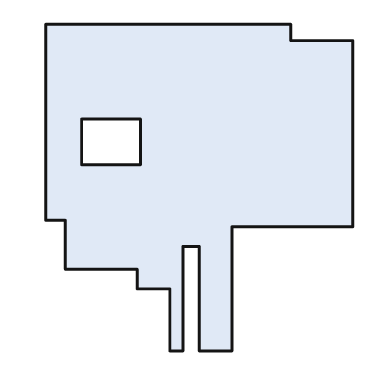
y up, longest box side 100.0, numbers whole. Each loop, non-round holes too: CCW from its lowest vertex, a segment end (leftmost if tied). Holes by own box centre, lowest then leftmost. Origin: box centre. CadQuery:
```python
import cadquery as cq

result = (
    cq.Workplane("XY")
    .moveTo(-9.0, -50.0)
    .lineTo(-5.0, -50.0)
    .lineTo(-5.0, -18.0)
    .lineTo(0.0, -18.0)
    .lineTo(0.0, -50.0)
    .lineTo(10.0, -50.0)
    .lineTo(10.0, -12.0)
    .lineTo(47.0, -12.0)
    .lineTo(47.0, 45.0)
    .lineTo(28.0, 45.0)
    .lineTo(28.0, 50.0)
    .lineTo(-47.0, 50.0)
    .lineTo(-47.0, -10.0)
    .lineTo(-41.0, -10.0)
    .lineTo(-41.0, -25.0)
    .lineTo(-19.0, -25.0)
    .lineTo(-19.0, -31.0)
    .lineTo(-9.0, -31.0)
    .close()
    .moveTo(-36.0, 7.0)
    .lineTo(-18.0, 7.0)
    .lineTo(-18.0, 21.0)
    .lineTo(-36.0, 21.0)
    .close()
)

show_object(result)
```